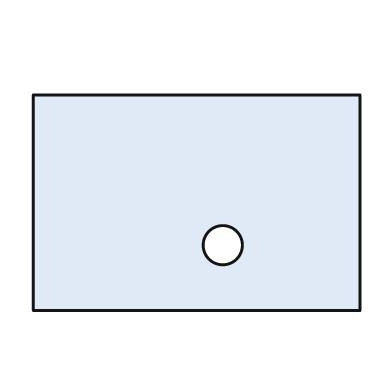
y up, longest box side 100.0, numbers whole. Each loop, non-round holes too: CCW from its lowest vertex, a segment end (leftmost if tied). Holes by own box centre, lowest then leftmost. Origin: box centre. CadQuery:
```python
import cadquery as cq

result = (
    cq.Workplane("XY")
    .moveTo(-50.0, -33.0)
    .lineTo(50.0, -33.0)
    .lineTo(50.0, 33.0)
    .lineTo(-50.0, 33.0)
    .close()
    .moveTo(8.0, -13.0)
    .circle(6.0)
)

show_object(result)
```